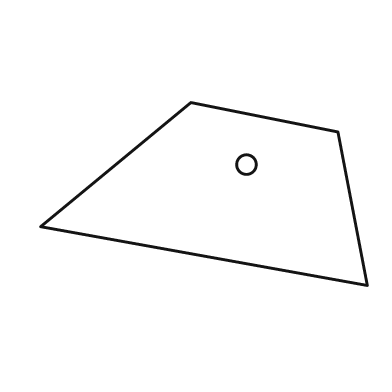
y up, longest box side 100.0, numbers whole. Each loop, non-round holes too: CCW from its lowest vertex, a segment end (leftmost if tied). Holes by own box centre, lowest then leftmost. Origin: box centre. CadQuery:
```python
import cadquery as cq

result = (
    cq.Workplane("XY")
    .moveTo(50.0, -28.0)
    .lineTo(41.0, 19.0)
    .lineTo(-4.0, 28.0)
    .lineTo(-50.0, -10.0)
    .close()
    .moveTo(13.0, 9.0)
    .circle(3.0)
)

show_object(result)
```